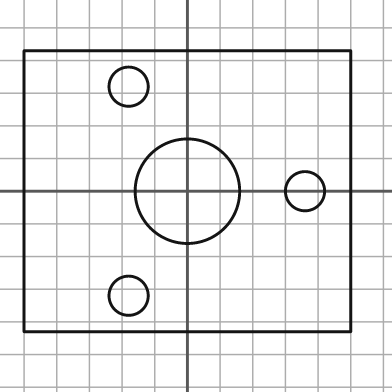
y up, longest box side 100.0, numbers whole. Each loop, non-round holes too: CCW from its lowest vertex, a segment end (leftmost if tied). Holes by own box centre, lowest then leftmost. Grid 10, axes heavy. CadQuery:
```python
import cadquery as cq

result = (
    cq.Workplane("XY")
    .moveTo(-50.0, -43.0)
    .lineTo(50.0, -43.0)
    .lineTo(50.0, 43.0)
    .lineTo(-50.0, 43.0)
    .close()
    .moveTo(-18.0, -32.0)
    .circle(6.0)
    .moveTo(0.0, 0.0)
    .circle(16.0)
    .moveTo(36.0, 0.0)
    .circle(6.0)
    .moveTo(-18.0, 32.0)
    .circle(6.0)
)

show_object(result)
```